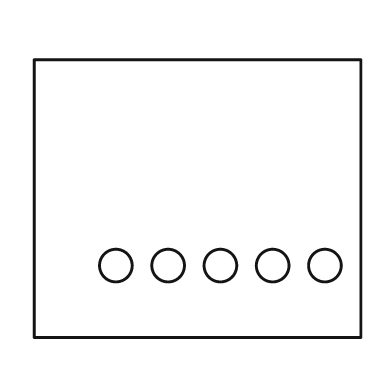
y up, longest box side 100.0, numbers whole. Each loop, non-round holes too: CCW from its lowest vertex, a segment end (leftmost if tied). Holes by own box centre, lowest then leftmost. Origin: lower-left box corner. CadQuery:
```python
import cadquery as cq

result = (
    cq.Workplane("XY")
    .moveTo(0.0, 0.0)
    .lineTo(100.0, 0.0)
    .lineTo(100.0, 85.0)
    .lineTo(0.0, 85.0)
    .close()
    .moveTo(25.0, 22.0)
    .circle(5.0)
    .moveTo(41.0, 22.0)
    .circle(5.0)
    .moveTo(57.0, 22.0)
    .circle(5.0)
    .moveTo(73.0, 22.0)
    .circle(5.0)
    .moveTo(89.0, 22.0)
    .circle(5.0)
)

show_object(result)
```